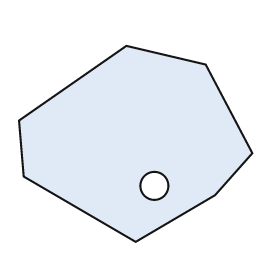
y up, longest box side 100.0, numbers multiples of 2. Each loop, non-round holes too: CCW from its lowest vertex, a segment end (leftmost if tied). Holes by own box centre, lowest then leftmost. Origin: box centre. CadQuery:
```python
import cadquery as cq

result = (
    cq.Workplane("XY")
    .moveTo(0.0, -42.0)
    .lineTo(34.0, -22.0)
    .lineTo(50.0, -4.0)
    .lineTo(30.0, 34.0)
    .lineTo(-4.0, 42.0)
    .lineTo(-50.0, 10.0)
    .lineTo(-48.0, -14.0)
    .close()
    .moveTo(8.0, -18.0)
    .circle(6.0)
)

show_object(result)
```